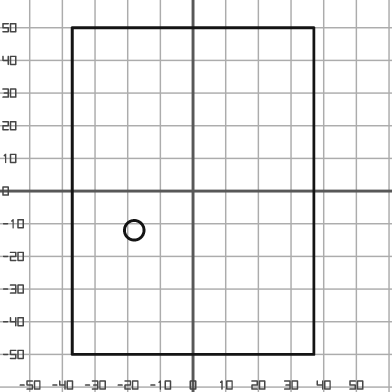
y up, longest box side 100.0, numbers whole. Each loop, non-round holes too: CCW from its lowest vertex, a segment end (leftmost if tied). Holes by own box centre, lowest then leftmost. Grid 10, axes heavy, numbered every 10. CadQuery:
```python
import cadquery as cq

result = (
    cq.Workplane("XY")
    .moveTo(-37.0, -50.0)
    .lineTo(37.0, -50.0)
    .lineTo(37.0, 50.0)
    .lineTo(-37.0, 50.0)
    .close()
    .moveTo(-18.0, -12.0)
    .circle(3.0)
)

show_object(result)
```